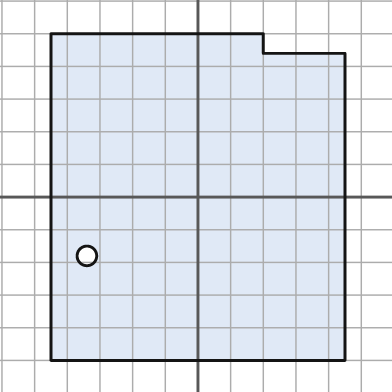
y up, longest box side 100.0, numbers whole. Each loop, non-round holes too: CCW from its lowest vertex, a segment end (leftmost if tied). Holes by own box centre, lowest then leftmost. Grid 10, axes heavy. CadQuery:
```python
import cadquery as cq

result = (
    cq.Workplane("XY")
    .moveTo(-45.0, -50.0)
    .lineTo(45.0, -50.0)
    .lineTo(45.0, 44.0)
    .lineTo(20.0, 44.0)
    .lineTo(20.0, 50.0)
    .lineTo(-45.0, 50.0)
    .close()
    .moveTo(-34.0, -18.0)
    .circle(3.0)
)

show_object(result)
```